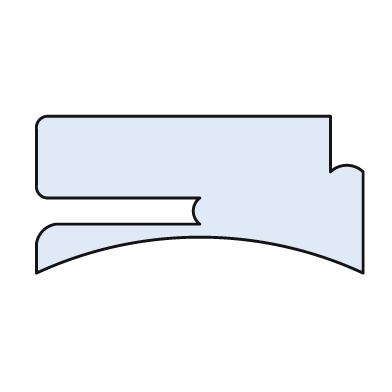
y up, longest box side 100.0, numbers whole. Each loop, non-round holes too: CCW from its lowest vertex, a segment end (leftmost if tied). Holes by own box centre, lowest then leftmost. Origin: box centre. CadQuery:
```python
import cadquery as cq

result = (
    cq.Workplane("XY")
    .moveTo(-50.0, -24.0)
    .threePointArc((0.0, -13.0), (50.0, -24.0))
    .lineTo(50.0, 7.0)
    .threePointArc((45.0, 9.0), (40.0, 7.0))
    .lineTo(40.0, 24.0)
    .lineTo(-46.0, 24.0)
    .threePointArc((-49.0, 23.0), (-50.0, 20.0))
    .lineTo(-50.0, 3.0)
    .threePointArc((-49.0, 0.0), (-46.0, -1.0))
    .lineTo(0.0, -1.0)
    .threePointArc((-2.0, -5.0), (0.0, -9.0))
    .lineTo(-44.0, -9.0)
    .threePointArc((-48.0, -11.0), (-50.0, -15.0))
    .close()
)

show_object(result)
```